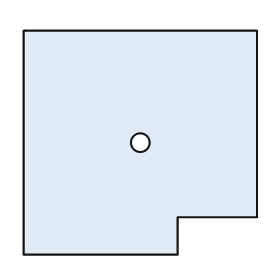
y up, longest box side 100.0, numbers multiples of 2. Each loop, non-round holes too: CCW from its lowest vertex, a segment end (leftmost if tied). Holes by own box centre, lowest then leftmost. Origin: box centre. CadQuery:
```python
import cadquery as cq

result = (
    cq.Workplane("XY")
    .moveTo(-50.0, -48.0)
    .lineTo(16.0, -48.0)
    .lineTo(16.0, -32.0)
    .lineTo(50.0, -32.0)
    .lineTo(50.0, 48.0)
    .lineTo(-50.0, 48.0)
    .close()
    .moveTo(0.0, 0.0)
    .circle(4.0)
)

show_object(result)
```